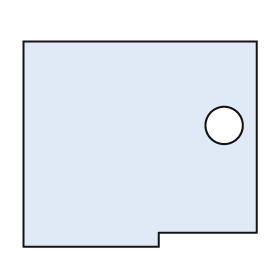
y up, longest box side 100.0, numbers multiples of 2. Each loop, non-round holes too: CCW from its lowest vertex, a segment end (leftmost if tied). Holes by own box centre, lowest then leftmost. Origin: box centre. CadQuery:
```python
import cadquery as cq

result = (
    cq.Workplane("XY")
    .moveTo(-50.0, -44.0)
    .lineTo(8.0, -44.0)
    .lineTo(8.0, -38.0)
    .lineTo(50.0, -38.0)
    .lineTo(50.0, 44.0)
    .lineTo(-50.0, 44.0)
    .close()
    .moveTo(36.0, 8.0)
    .circle(8.0)
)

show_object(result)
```